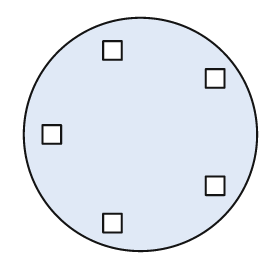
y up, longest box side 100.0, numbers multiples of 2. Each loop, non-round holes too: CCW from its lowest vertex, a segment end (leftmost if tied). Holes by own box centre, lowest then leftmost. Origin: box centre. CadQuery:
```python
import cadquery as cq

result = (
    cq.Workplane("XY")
    .moveTo(0.0, 0.0)
    .circle(50.0)
    .moveTo(-16.0, -42.0)
    .lineTo(-8.0, -42.0)
    .lineTo(-8.0, -34.0)
    .lineTo(-16.0, -34.0)
    .close()
    .moveTo(28.0, -26.0)
    .lineTo(36.0, -26.0)
    .lineTo(36.0, -18.0)
    .lineTo(28.0, -18.0)
    .close()
    .moveTo(-42.0, -4.0)
    .lineTo(-34.0, -4.0)
    .lineTo(-34.0, 4.0)
    .lineTo(-42.0, 4.0)
    .close()
    .moveTo(28.0, 20.0)
    .lineTo(36.0, 20.0)
    .lineTo(36.0, 28.0)
    .lineTo(28.0, 28.0)
    .close()
    .moveTo(-16.0, 32.0)
    .lineTo(-8.0, 32.0)
    .lineTo(-8.0, 40.0)
    .lineTo(-16.0, 40.0)
    .close()
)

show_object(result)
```